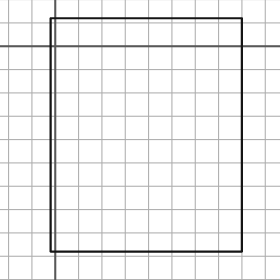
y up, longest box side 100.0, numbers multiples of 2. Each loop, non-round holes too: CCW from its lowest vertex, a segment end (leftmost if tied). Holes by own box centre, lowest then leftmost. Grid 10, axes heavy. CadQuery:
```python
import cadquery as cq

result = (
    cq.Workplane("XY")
    .moveTo(-2.0, -88.0)
    .lineTo(80.0, -88.0)
    .lineTo(80.0, 12.0)
    .lineTo(-2.0, 12.0)
    .close()
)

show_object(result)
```